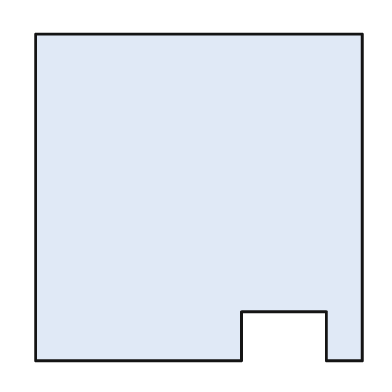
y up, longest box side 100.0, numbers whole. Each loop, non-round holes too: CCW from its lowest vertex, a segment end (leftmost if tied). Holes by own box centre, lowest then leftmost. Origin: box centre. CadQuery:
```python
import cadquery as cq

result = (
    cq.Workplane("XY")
    .moveTo(-50.0, -50.0)
    .lineTo(13.0, -50.0)
    .lineTo(13.0, -35.0)
    .lineTo(39.0, -35.0)
    .lineTo(39.0, -50.0)
    .lineTo(50.0, -50.0)
    .lineTo(50.0, 50.0)
    .lineTo(-50.0, 50.0)
    .close()
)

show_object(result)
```